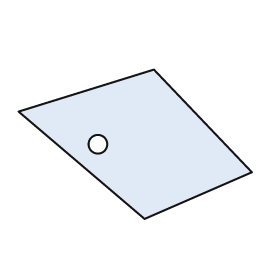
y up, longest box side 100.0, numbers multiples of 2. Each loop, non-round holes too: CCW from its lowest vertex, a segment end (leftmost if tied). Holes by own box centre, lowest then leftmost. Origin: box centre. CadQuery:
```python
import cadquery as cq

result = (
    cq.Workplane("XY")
    .moveTo(4.0, -32.0)
    .lineTo(50.0, -12.0)
    .lineTo(8.0, 32.0)
    .lineTo(-50.0, 14.0)
    .close()
    .moveTo(-16.0, 0.0)
    .circle(4.0)
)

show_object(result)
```